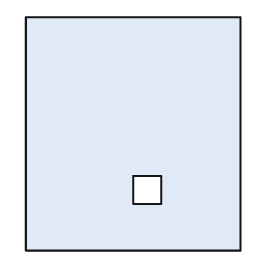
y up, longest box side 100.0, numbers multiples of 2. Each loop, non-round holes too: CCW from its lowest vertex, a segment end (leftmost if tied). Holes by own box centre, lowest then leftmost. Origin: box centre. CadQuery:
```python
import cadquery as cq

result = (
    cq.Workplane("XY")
    .moveTo(-46.0, -50.0)
    .lineTo(46.0, -50.0)
    .lineTo(46.0, 50.0)
    .lineTo(-46.0, 50.0)
    .close()
    .moveTo(0.0, -30.0)
    .lineTo(12.0, -30.0)
    .lineTo(12.0, -18.0)
    .lineTo(0.0, -18.0)
    .close()
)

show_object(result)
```